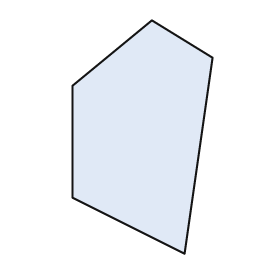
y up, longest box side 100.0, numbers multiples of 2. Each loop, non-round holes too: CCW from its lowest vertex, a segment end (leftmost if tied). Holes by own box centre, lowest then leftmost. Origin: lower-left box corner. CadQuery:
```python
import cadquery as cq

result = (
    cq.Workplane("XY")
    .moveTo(48.0, 0.0)
    .lineTo(60.0, 84.0)
    .lineTo(34.0, 100.0)
    .lineTo(0.0, 72.0)
    .lineTo(0.0, 24.0)
    .close()
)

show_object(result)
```